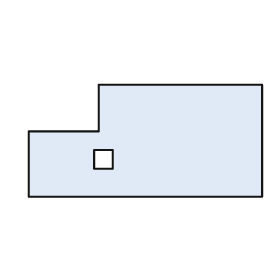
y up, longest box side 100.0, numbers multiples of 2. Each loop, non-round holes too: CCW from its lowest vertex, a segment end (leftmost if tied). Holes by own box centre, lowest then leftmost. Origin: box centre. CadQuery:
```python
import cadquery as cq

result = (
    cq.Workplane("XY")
    .moveTo(-50.0, -24.0)
    .lineTo(50.0, -24.0)
    .lineTo(50.0, 24.0)
    .lineTo(-20.0, 24.0)
    .lineTo(-20.0, 4.0)
    .lineTo(-50.0, 4.0)
    .close()
    .moveTo(-22.0, -12.0)
    .lineTo(-14.0, -12.0)
    .lineTo(-14.0, -4.0)
    .lineTo(-22.0, -4.0)
    .close()
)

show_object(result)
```